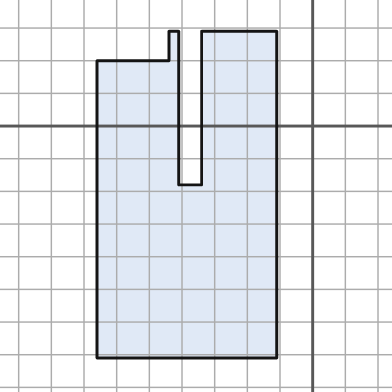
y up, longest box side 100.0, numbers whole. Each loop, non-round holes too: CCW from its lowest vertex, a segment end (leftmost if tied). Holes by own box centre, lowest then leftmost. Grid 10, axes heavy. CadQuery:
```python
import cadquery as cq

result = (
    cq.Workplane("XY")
    .moveTo(-66.0, -71.0)
    .lineTo(-11.0, -71.0)
    .lineTo(-11.0, 29.0)
    .lineTo(-34.0, 29.0)
    .lineTo(-34.0, -18.0)
    .lineTo(-41.0, -18.0)
    .lineTo(-41.0, 29.0)
    .lineTo(-44.0, 29.0)
    .lineTo(-44.0, 20.0)
    .lineTo(-66.0, 20.0)
    .close()
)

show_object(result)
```